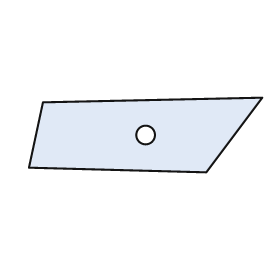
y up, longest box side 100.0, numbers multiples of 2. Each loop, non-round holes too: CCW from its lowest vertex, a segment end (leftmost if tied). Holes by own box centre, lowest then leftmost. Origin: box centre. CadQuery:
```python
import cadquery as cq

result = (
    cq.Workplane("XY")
    .moveTo(26.0, -16.0)
    .lineTo(50.0, 16.0)
    .lineTo(-44.0, 14.0)
    .lineTo(-50.0, -14.0)
    .close()
    .moveTo(0.0, 0.0)
    .circle(4.0)
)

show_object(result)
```